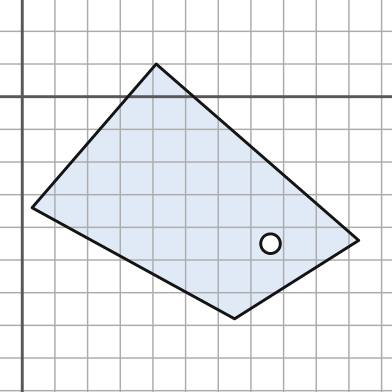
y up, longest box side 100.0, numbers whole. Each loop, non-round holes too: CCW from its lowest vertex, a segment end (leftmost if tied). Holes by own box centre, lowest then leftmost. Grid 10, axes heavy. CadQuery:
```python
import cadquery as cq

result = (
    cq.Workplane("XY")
    .moveTo(65.0, -68.0)
    .lineTo(103.0, -44.0)
    .lineTo(41.0, 10.0)
    .lineTo(3.0, -34.0)
    .close()
    .moveTo(76.0, -45.0)
    .circle(3.0)
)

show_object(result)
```